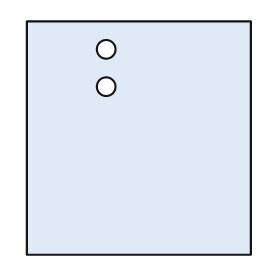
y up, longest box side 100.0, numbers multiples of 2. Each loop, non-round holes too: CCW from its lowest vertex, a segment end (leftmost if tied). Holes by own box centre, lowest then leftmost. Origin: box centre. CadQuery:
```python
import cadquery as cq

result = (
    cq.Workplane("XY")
    .moveTo(-48.0, -50.0)
    .lineTo(48.0, -50.0)
    .lineTo(48.0, 50.0)
    .lineTo(-48.0, 50.0)
    .close()
    .moveTo(-14.0, 22.0)
    .circle(4.0)
    .moveTo(-14.0, 38.0)
    .circle(4.0)
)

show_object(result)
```